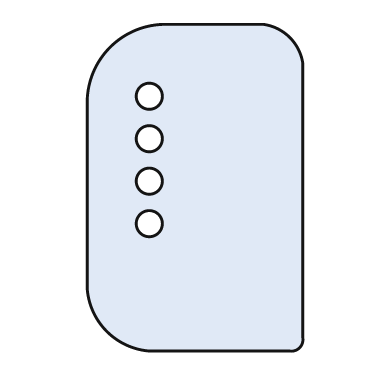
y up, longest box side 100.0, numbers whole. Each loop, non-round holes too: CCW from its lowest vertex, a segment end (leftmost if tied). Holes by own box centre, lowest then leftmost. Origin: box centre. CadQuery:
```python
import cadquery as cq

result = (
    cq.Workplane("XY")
    .moveTo(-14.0, -50.0)
    .lineTo(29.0, -50.0)
    .threePointArc((32.0, -49.0), (33.0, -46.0))
    .lineTo(33.0, 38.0)
    .threePointArc((29.0, 46.0), (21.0, 50.0))
    .lineTo(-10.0, 50.0)
    .threePointArc((-26.0, 43.0), (-33.0, 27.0))
    .lineTo(-33.0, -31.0)
    .threePointArc((-27.0, -44.0), (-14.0, -50.0))
    .close()
    .moveTo(-14.0, -11.0)
    .circle(4.0)
    .moveTo(-14.0, 2.0)
    .circle(4.0)
    .moveTo(-14.0, 15.0)
    .circle(4.0)
    .moveTo(-14.0, 28.0)
    .circle(4.0)
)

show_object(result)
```